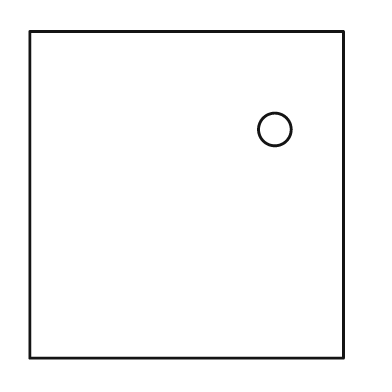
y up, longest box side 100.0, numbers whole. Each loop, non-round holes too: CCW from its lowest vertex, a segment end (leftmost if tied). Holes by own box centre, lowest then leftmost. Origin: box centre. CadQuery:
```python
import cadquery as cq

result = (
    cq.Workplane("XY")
    .moveTo(-48.0, -50.0)
    .lineTo(48.0, -50.0)
    .lineTo(48.0, 50.0)
    .lineTo(-48.0, 50.0)
    .close()
    .moveTo(27.0, 20.0)
    .circle(5.0)
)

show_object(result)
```